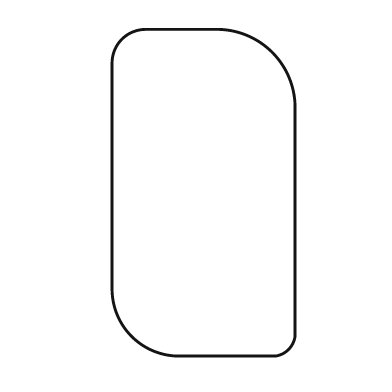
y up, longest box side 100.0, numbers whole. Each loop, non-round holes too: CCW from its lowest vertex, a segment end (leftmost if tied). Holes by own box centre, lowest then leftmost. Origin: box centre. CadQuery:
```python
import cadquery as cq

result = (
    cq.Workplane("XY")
    .moveTo(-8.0, -50.0)
    .lineTo(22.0, -50.0)
    .threePointArc((26.0, -48.0), (28.0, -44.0))
    .lineTo(28.0, 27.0)
    .threePointArc((21.0, 43.0), (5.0, 50.0))
    .lineTo(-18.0, 50.0)
    .threePointArc((-25.0, 47.0), (-28.0, 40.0))
    .lineTo(-28.0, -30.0)
    .threePointArc((-22.0, -44.0), (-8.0, -50.0))
    .close()
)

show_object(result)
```